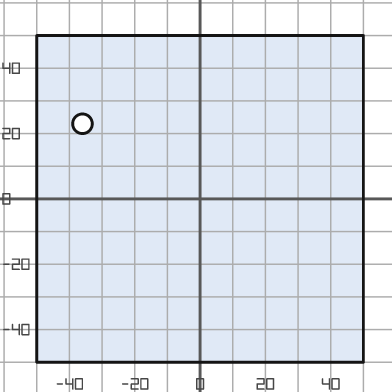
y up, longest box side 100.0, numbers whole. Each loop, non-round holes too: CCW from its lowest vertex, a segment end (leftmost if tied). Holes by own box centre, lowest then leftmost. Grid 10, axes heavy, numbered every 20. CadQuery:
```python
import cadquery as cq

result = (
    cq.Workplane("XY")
    .moveTo(-50.0, -50.0)
    .lineTo(50.0, -50.0)
    .lineTo(50.0, 50.0)
    .lineTo(-50.0, 50.0)
    .close()
    .moveTo(-36.0, 23.0)
    .circle(3.0)
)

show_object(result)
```